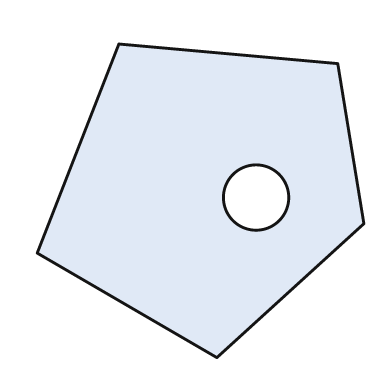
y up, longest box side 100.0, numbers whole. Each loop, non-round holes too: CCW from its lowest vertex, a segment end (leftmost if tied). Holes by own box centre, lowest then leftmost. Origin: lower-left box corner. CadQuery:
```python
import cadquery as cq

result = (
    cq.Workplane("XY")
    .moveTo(55.0, 0.0)
    .lineTo(100.0, 41.0)
    .lineTo(92.0, 90.0)
    .lineTo(25.0, 96.0)
    .lineTo(0.0, 32.0)
    .close()
    .moveTo(67.0, 49.0)
    .circle(10.0)
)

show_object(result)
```